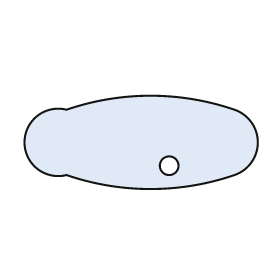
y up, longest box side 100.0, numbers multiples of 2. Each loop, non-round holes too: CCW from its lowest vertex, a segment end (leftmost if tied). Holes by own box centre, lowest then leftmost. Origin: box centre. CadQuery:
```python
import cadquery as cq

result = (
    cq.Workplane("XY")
    .moveTo(-32.0, -14.0)
    .threePointArc((4.0, -20.0), (40.0, -14.0))
    .threePointArc((50.0, 0.0), (40.0, 14.0))
    .threePointArc((4.0, 20.0), (-32.0, 14.0))
    .threePointArc((-50.0, 0.0), (-32.0, -14.0))
    .close()
    .moveTo(12.0, -10.0)
    .circle(4.0)
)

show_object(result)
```